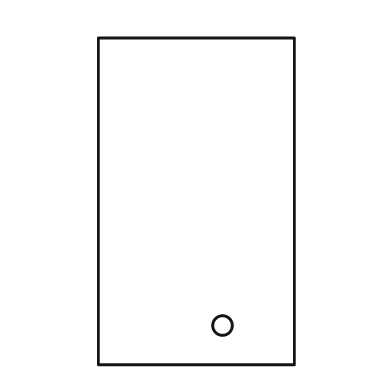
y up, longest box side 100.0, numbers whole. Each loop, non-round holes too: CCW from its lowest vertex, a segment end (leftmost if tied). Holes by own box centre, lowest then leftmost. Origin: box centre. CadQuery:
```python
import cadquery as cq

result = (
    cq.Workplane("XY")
    .moveTo(-30.0, -50.0)
    .lineTo(30.0, -50.0)
    .lineTo(30.0, 50.0)
    .lineTo(-30.0, 50.0)
    .close()
    .moveTo(8.0, -38.0)
    .circle(3.0)
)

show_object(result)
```